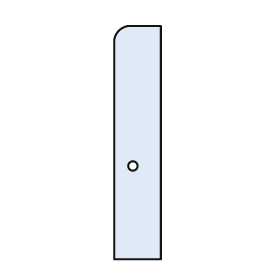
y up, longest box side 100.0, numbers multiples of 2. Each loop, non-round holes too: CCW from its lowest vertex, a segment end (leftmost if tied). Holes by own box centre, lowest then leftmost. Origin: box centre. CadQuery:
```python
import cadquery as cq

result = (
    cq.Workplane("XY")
    .moveTo(-10.0, -50.0)
    .lineTo(10.0, -50.0)
    .lineTo(10.0, 50.0)
    .lineTo(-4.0, 50.0)
    .threePointArc((-8.0, 48.0), (-10.0, 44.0))
    .close()
    .moveTo(-2.0, -10.0)
    .circle(2.0)
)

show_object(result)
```